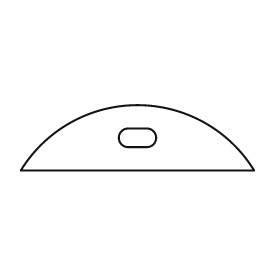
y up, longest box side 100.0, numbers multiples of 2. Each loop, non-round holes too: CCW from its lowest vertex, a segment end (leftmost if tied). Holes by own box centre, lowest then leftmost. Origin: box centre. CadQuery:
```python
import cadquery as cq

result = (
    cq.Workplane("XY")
    .moveTo(-50.0, -14.0)
    .lineTo(50.0, -14.0)
    .threePointArc((0.0, 14.0), (-50.0, -14.0))
    .close()
    .moveTo(-4.0, -4.0)
    .lineTo(4.0, -4.0)
    .threePointArc((8.0, 0.0), (4.0, 4.0))
    .lineTo(-4.0, 4.0)
    .threePointArc((-8.0, 0.0), (-4.0, -4.0))
    .close()
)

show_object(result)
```